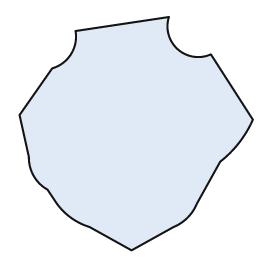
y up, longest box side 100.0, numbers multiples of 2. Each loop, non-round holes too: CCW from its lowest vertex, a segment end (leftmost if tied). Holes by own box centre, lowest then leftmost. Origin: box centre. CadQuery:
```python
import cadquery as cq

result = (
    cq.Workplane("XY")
    .moveTo(-2.0, -50.0)
    .lineTo(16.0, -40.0)
    .threePointArc((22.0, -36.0), (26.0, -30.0))
    .lineTo(36.0, -12.0)
    .threePointArc((44.0, -4.0), (50.0, 6.0))
    .lineTo(32.0, 34.0)
    .threePointArc((18.0, 36.0), (14.0, 50.0))
    .lineTo(-26.0, 44.0)
    .threePointArc((-28.0, 34.0), (-36.0, 28.0))
    .lineTo(-50.0, 8.0)
    .lineTo(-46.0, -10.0)
    .threePointArc((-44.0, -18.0), (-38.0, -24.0))
    .lineTo(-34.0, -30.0)
    .threePointArc((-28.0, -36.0), (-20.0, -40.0))
    .close()
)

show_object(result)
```